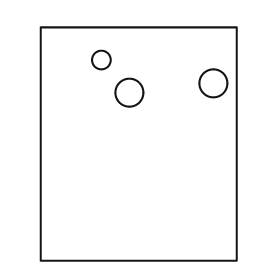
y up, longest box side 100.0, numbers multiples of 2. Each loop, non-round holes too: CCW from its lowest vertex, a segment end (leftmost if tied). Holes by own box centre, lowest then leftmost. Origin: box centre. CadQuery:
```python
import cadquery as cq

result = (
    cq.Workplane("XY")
    .moveTo(-42.0, -50.0)
    .lineTo(42.0, -50.0)
    .lineTo(42.0, 50.0)
    .lineTo(-42.0, 50.0)
    .close()
    .moveTo(-4.0, 22.0)
    .circle(6.0)
    .moveTo(32.0, 26.0)
    .circle(6.0)
    .moveTo(-16.0, 36.0)
    .circle(4.0)
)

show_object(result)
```